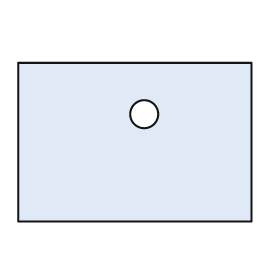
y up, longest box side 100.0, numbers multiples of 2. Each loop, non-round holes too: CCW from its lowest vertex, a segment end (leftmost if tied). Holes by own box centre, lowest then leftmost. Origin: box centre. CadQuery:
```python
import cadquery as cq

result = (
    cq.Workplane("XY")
    .moveTo(-50.0, -34.0)
    .lineTo(50.0, -34.0)
    .lineTo(50.0, 34.0)
    .lineTo(-50.0, 34.0)
    .close()
    .moveTo(4.0, 12.0)
    .circle(6.0)
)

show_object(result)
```